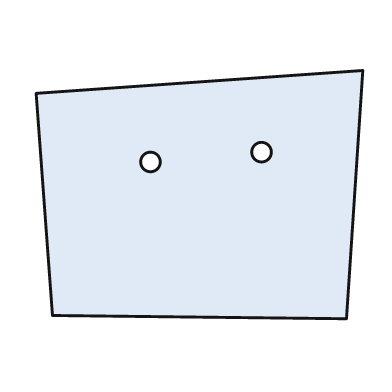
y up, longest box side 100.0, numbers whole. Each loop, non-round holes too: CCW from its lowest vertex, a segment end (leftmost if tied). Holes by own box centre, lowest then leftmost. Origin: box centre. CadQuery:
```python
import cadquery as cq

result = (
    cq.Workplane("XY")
    .moveTo(45.0, -38.0)
    .lineTo(50.0, 38.0)
    .lineTo(-50.0, 31.0)
    .lineTo(-45.0, -37.0)
    .close()
    .moveTo(-15.0, 10.0)
    .circle(3.0)
    .moveTo(19.0, 13.0)
    .circle(3.0)
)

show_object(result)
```